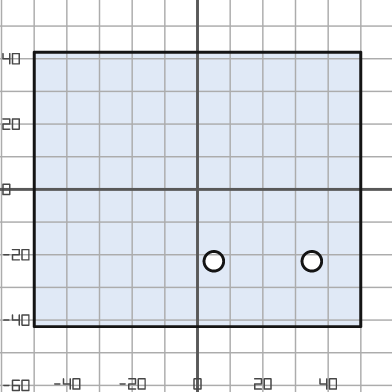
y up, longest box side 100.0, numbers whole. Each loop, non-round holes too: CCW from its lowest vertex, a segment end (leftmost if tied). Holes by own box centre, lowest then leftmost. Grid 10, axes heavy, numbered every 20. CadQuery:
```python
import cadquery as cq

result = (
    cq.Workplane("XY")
    .moveTo(-50.0, -42.0)
    .lineTo(50.0, -42.0)
    .lineTo(50.0, 42.0)
    .lineTo(-50.0, 42.0)
    .close()
    .moveTo(5.0, -22.0)
    .circle(3.0)
    .moveTo(35.0, -22.0)
    .circle(3.0)
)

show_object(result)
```